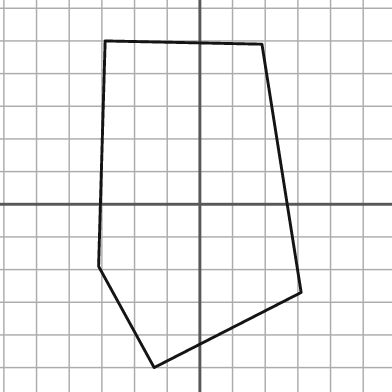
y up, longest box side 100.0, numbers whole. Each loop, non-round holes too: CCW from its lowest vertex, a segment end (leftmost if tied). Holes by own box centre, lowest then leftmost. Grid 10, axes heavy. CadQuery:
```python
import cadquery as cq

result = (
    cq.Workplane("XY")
    .moveTo(-14.0, -50.0)
    .lineTo(31.0, -27.0)
    .lineTo(19.0, 49.0)
    .lineTo(-29.0, 50.0)
    .lineTo(-31.0, -19.0)
    .close()
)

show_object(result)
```